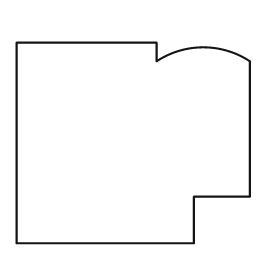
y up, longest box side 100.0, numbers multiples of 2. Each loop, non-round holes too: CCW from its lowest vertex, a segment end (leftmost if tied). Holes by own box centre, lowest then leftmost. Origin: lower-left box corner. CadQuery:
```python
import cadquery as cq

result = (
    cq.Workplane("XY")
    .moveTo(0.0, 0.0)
    .lineTo(76.0, 0.0)
    .lineTo(76.0, 20.0)
    .lineTo(100.0, 20.0)
    .lineTo(100.0, 78.0)
    .threePointArc((80.0, 84.0), (60.0, 78.0))
    .lineTo(60.0, 86.0)
    .lineTo(0.0, 86.0)
    .close()
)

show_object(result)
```